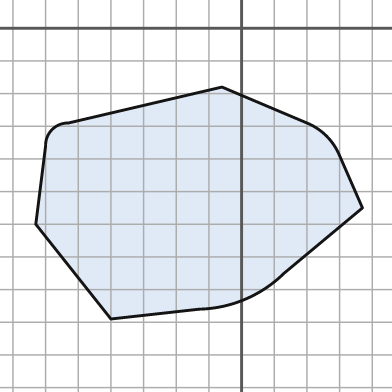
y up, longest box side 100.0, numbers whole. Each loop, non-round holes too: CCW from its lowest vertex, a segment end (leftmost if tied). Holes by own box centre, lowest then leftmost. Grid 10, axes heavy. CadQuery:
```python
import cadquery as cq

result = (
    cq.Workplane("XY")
    .moveTo(-40.0, -89.0)
    .lineTo(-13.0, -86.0)
    .threePointArc((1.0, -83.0), (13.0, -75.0))
    .lineTo(37.0, -55.0)
    .lineTo(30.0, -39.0)
    .threePointArc((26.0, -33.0), (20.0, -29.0))
    .lineTo(-6.0, -18.0)
    .lineTo(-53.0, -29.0)
    .threePointArc((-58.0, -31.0), (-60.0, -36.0))
    .lineTo(-63.0, -60.0)
    .close()
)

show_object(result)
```